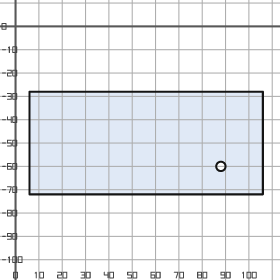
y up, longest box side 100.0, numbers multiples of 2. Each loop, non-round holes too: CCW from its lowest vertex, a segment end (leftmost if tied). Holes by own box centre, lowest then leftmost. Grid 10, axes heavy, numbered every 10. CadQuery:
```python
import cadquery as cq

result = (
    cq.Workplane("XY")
    .moveTo(6.0, -72.0)
    .lineTo(106.0, -72.0)
    .lineTo(106.0, -28.0)
    .lineTo(6.0, -28.0)
    .close()
    .moveTo(88.0, -60.0)
    .circle(2.0)
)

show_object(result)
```